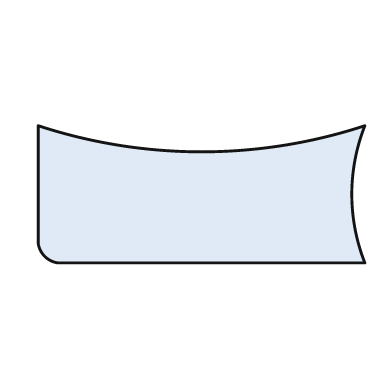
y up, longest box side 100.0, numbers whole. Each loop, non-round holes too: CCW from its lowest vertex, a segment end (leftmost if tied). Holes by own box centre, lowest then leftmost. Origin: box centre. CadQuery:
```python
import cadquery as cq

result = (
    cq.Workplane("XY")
    .moveTo(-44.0, -21.0)
    .lineTo(50.0, -21.0)
    .threePointArc((46.0, 0.0), (50.0, 21.0))
    .threePointArc((0.0, 13.0), (-50.0, 21.0))
    .lineTo(-50.0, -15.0)
    .threePointArc((-48.0, -19.0), (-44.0, -21.0))
    .close()
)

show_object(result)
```